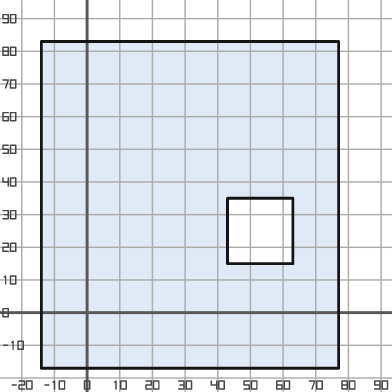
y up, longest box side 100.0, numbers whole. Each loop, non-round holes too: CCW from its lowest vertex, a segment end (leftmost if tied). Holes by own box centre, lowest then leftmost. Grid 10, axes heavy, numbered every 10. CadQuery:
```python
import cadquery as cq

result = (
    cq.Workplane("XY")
    .moveTo(-14.0, -17.0)
    .lineTo(77.0, -17.0)
    .lineTo(77.0, 83.0)
    .lineTo(-14.0, 83.0)
    .close()
    .moveTo(43.0, 15.0)
    .lineTo(63.0, 15.0)
    .lineTo(63.0, 35.0)
    .lineTo(43.0, 35.0)
    .close()
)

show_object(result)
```